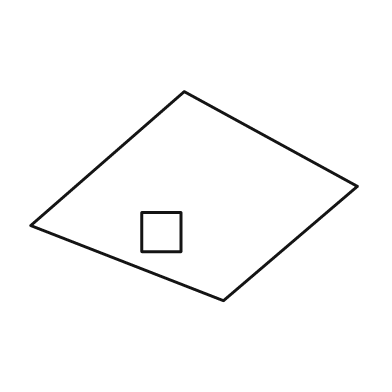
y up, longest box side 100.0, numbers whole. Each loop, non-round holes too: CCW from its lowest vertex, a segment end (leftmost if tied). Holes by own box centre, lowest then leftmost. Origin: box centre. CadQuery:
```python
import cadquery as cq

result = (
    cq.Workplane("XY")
    .moveTo(9.0, -32.0)
    .lineTo(50.0, 3.0)
    .lineTo(-3.0, 32.0)
    .lineTo(-50.0, -9.0)
    .close()
    .moveTo(-16.0, -17.0)
    .lineTo(-4.0, -17.0)
    .lineTo(-4.0, -5.0)
    .lineTo(-16.0, -5.0)
    .close()
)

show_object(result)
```